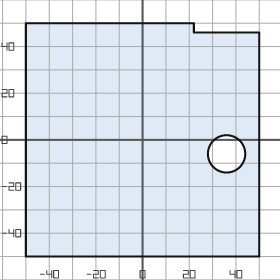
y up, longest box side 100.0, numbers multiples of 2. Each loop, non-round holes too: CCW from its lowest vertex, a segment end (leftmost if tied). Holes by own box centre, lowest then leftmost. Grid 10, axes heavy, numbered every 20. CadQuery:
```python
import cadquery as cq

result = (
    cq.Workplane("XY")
    .moveTo(-50.0, -50.0)
    .lineTo(50.0, -50.0)
    .lineTo(50.0, 46.0)
    .lineTo(22.0, 46.0)
    .lineTo(22.0, 50.0)
    .lineTo(-50.0, 50.0)
    .close()
    .moveTo(36.0, -6.0)
    .circle(8.0)
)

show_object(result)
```